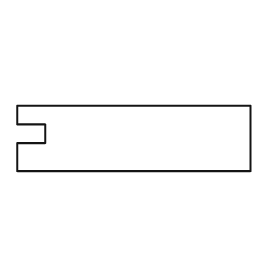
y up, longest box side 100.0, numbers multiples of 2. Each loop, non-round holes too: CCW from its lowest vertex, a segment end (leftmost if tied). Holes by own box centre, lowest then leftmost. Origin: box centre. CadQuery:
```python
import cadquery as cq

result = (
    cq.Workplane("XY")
    .moveTo(-50.0, -14.0)
    .lineTo(50.0, -14.0)
    .lineTo(50.0, 14.0)
    .lineTo(-50.0, 14.0)
    .lineTo(-50.0, 6.0)
    .lineTo(-38.0, 6.0)
    .lineTo(-38.0, -2.0)
    .lineTo(-50.0, -2.0)
    .close()
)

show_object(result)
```